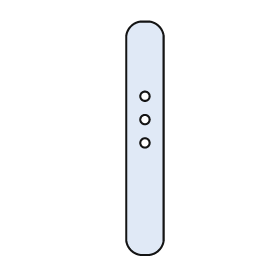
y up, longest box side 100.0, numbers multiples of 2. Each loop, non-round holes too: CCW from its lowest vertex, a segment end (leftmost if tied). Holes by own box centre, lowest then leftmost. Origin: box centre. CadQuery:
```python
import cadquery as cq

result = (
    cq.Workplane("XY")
    .moveTo(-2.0, -50.0)
    .lineTo(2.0, -50.0)
    .threePointArc((6.0, -48.0), (8.0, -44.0))
    .lineTo(8.0, 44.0)
    .threePointArc((6.0, 48.0), (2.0, 50.0))
    .lineTo(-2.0, 50.0)
    .threePointArc((-6.0, 48.0), (-8.0, 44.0))
    .lineTo(-8.0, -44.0)
    .threePointArc((-6.0, -48.0), (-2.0, -50.0))
    .close()
    .moveTo(0.0, -2.0)
    .circle(2.0)
    .moveTo(0.0, 8.0)
    .circle(2.0)
    .moveTo(0.0, 18.0)
    .circle(2.0)
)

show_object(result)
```